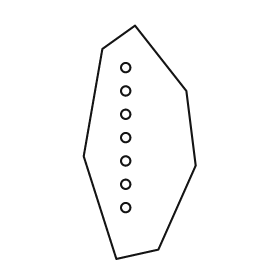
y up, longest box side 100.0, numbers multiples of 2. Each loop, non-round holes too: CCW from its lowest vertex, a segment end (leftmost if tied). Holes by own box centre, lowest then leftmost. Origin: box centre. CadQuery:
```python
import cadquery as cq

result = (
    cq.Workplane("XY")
    .moveTo(-10.0, -50.0)
    .lineTo(8.0, -46.0)
    .lineTo(24.0, -10.0)
    .lineTo(20.0, 22.0)
    .lineTo(-2.0, 50.0)
    .lineTo(-16.0, 40.0)
    .lineTo(-24.0, -6.0)
    .close()
    .moveTo(-6.0, -28.0)
    .circle(2.0)
    .moveTo(-6.0, -18.0)
    .circle(2.0)
    .moveTo(-6.0, -8.0)
    .circle(2.0)
    .moveTo(-6.0, 2.0)
    .circle(2.0)
    .moveTo(-6.0, 12.0)
    .circle(2.0)
    .moveTo(-6.0, 22.0)
    .circle(2.0)
    .moveTo(-6.0, 32.0)
    .circle(2.0)
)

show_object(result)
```